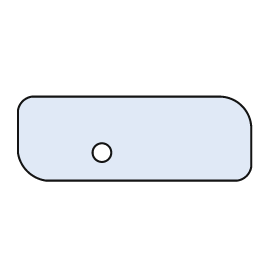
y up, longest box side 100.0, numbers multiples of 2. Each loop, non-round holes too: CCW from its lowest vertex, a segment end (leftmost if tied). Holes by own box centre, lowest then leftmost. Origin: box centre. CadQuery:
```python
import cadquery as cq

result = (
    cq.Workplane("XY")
    .moveTo(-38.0, -18.0)
    .lineTo(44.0, -18.0)
    .threePointArc((48.0, -16.0), (50.0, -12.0))
    .lineTo(50.0, 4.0)
    .threePointArc((46.0, 14.0), (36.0, 18.0))
    .lineTo(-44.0, 18.0)
    .threePointArc((-48.0, 16.0), (-50.0, 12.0))
    .lineTo(-50.0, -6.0)
    .threePointArc((-46.0, -14.0), (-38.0, -18.0))
    .close()
    .moveTo(-14.0, -6.0)
    .circle(4.0)
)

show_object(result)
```